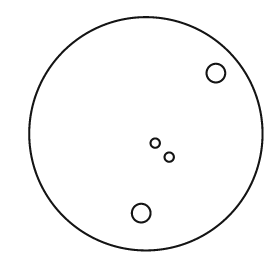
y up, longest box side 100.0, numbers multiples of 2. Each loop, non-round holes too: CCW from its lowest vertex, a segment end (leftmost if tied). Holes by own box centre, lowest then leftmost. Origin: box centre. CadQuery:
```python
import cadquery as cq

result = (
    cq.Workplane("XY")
    .moveTo(0.0, 0.0)
    .circle(50.0)
    .moveTo(-2.0, -34.0)
    .circle(4.0)
    .moveTo(10.0, -10.0)
    .circle(2.0)
    .moveTo(4.0, -4.0)
    .circle(2.0)
    .moveTo(30.0, 26.0)
    .circle(4.0)
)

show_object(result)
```